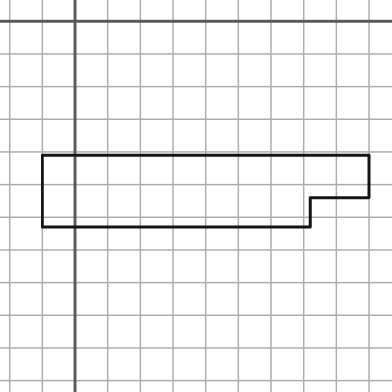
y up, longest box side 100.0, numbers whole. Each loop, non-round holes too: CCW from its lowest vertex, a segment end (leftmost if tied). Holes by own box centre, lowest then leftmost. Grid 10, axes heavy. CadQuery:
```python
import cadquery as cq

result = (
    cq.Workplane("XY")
    .moveTo(-10.0, -63.0)
    .lineTo(72.0, -63.0)
    .lineTo(72.0, -54.0)
    .lineTo(90.0, -54.0)
    .lineTo(90.0, -41.0)
    .lineTo(-10.0, -41.0)
    .close()
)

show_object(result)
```